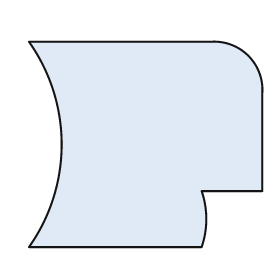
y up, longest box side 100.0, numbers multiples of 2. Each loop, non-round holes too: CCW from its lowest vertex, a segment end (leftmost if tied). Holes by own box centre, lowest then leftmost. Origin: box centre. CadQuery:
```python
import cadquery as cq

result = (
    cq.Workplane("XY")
    .moveTo(-50.0, -44.0)
    .lineTo(24.0, -44.0)
    .threePointArc((26.0, -32.0), (24.0, -20.0))
    .lineTo(50.0, -20.0)
    .lineTo(50.0, 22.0)
    .threePointArc((44.0, 38.0), (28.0, 44.0))
    .lineTo(-50.0, 44.0)
    .threePointArc((-36.0, 0.0), (-50.0, -44.0))
    .close()
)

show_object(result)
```